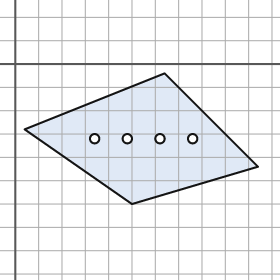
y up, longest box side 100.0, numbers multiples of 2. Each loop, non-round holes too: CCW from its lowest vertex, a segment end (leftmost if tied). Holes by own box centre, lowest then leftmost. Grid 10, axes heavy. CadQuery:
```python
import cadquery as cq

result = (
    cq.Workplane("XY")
    .moveTo(50.0, -60.0)
    .lineTo(104.0, -44.0)
    .lineTo(64.0, -4.0)
    .lineTo(4.0, -28.0)
    .close()
    .moveTo(34.0, -32.0)
    .circle(2.0)
    .moveTo(48.0, -32.0)
    .circle(2.0)
    .moveTo(62.0, -32.0)
    .circle(2.0)
    .moveTo(76.0, -32.0)
    .circle(2.0)
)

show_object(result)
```